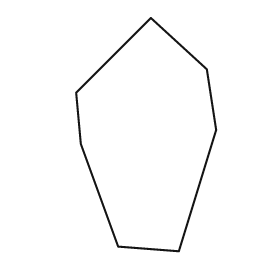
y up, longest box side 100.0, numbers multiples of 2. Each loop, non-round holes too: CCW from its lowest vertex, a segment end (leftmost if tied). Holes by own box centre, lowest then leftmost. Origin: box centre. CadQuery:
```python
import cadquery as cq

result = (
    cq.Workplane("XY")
    .moveTo(14.0, -50.0)
    .lineTo(30.0, 2.0)
    .lineTo(26.0, 28.0)
    .lineTo(2.0, 50.0)
    .lineTo(-30.0, 18.0)
    .lineTo(-28.0, -4.0)
    .lineTo(-12.0, -48.0)
    .close()
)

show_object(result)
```